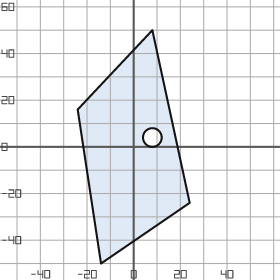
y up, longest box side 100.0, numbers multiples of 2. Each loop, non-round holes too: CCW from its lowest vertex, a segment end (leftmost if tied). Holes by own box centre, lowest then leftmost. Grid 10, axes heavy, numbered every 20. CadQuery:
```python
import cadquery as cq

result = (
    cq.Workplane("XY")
    .moveTo(-14.0, -50.0)
    .lineTo(24.0, -24.0)
    .lineTo(8.0, 50.0)
    .lineTo(-24.0, 16.0)
    .close()
    .moveTo(8.0, 4.0)
    .circle(4.0)
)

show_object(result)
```